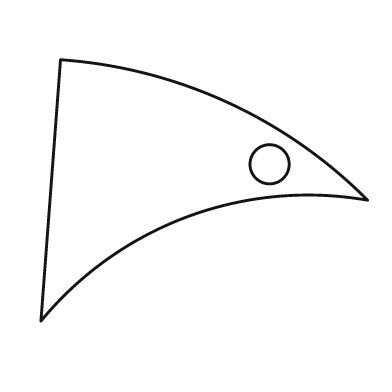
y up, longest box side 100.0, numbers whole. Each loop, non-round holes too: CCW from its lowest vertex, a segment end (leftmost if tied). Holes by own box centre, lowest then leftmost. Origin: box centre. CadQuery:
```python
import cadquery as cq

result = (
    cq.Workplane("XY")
    .moveTo(-50.0, -40.0)
    .threePointArc((-5.0, -8.0), (50.0, -3.0))
    .threePointArc((7.0, 27.0), (-44.0, 40.0))
    .close()
    .moveTo(20.0, 8.0)
    .circle(6.0)
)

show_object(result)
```